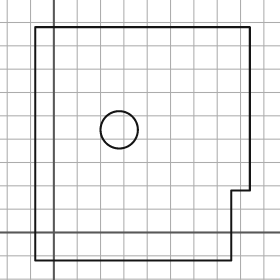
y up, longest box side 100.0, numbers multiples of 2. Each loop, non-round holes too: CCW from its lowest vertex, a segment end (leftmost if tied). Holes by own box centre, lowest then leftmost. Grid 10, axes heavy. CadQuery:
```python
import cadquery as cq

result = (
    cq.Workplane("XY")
    .moveTo(-8.0, -12.0)
    .lineTo(76.0, -12.0)
    .lineTo(76.0, 18.0)
    .lineTo(84.0, 18.0)
    .lineTo(84.0, 88.0)
    .lineTo(-8.0, 88.0)
    .close()
    .moveTo(28.0, 44.0)
    .circle(8.0)
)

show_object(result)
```